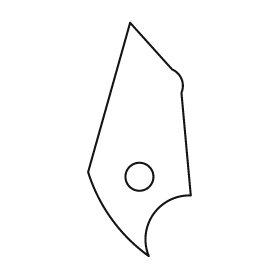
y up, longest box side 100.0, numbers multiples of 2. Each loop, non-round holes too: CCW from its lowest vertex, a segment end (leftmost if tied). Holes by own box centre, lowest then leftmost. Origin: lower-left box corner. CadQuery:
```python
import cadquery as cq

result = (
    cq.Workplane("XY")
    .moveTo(26.0, 0.0)
    .threePointArc((28.0, 18.0), (44.0, 26.0))
    .lineTo(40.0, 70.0)
    .threePointArc((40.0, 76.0), (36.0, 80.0))
    .lineTo(18.0, 100.0)
    .lineTo(0.0, 36.0)
    .threePointArc((10.0, 16.0), (26.0, 0.0))
    .close()
    .moveTo(22.0, 34.0)
    .circle(6.0)
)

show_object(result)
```